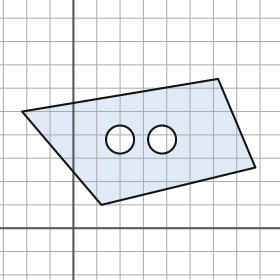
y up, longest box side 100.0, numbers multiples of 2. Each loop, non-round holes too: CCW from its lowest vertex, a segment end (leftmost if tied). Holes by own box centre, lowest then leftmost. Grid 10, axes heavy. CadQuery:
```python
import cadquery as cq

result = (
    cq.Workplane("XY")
    .moveTo(12.0, 10.0)
    .lineTo(78.0, 26.0)
    .lineTo(62.0, 64.0)
    .lineTo(-22.0, 50.0)
    .close()
    .moveTo(20.0, 38.0)
    .circle(6.0)
    .moveTo(38.0, 38.0)
    .circle(6.0)
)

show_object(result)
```